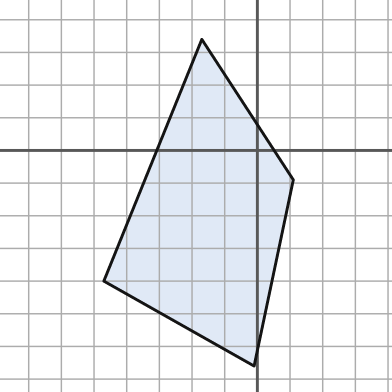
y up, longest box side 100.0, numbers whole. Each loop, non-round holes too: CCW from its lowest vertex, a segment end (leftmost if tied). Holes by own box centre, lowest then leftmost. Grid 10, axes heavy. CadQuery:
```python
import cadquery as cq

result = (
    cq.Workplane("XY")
    .moveTo(-1.0, -66.0)
    .lineTo(11.0, -9.0)
    .lineTo(-17.0, 34.0)
    .lineTo(-47.0, -40.0)
    .close()
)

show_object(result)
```